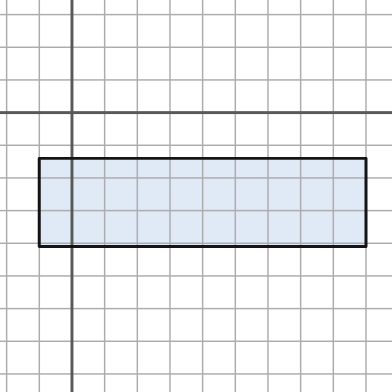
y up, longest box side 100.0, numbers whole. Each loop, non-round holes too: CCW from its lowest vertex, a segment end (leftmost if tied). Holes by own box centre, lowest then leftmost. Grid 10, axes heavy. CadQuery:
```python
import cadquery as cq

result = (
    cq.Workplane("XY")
    .moveTo(-10.0, -41.0)
    .lineTo(90.0, -41.0)
    .lineTo(90.0, -14.0)
    .lineTo(-10.0, -14.0)
    .close()
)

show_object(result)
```